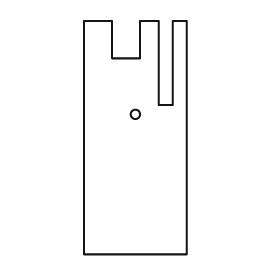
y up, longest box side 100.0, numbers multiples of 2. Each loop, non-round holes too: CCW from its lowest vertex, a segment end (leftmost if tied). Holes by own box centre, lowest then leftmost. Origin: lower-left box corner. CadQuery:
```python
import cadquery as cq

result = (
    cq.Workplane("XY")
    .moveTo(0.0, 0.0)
    .lineTo(44.0, 0.0)
    .lineTo(44.0, 100.0)
    .lineTo(38.0, 100.0)
    .lineTo(38.0, 64.0)
    .lineTo(32.0, 64.0)
    .lineTo(32.0, 100.0)
    .lineTo(24.0, 100.0)
    .lineTo(24.0, 84.0)
    .lineTo(12.0, 84.0)
    .lineTo(12.0, 100.0)
    .lineTo(0.0, 100.0)
    .close()
    .moveTo(22.0, 60.0)
    .circle(2.0)
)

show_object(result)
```